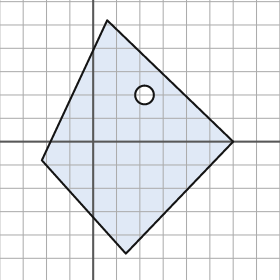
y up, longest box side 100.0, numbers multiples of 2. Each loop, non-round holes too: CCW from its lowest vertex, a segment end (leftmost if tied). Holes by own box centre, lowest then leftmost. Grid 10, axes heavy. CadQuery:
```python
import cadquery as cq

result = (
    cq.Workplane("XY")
    .moveTo(14.0, -48.0)
    .lineTo(60.0, 0.0)
    .lineTo(6.0, 52.0)
    .lineTo(-22.0, -8.0)
    .close()
    .moveTo(22.0, 20.0)
    .circle(4.0)
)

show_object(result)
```